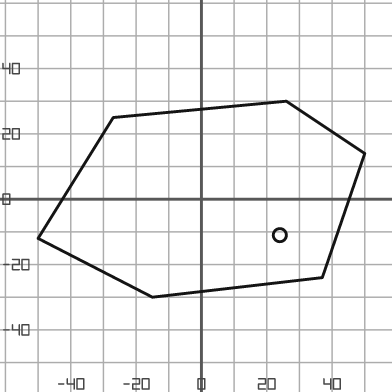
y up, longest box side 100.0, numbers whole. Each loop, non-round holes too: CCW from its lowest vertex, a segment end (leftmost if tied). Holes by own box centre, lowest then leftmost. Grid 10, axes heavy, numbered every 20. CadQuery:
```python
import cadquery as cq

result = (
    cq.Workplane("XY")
    .moveTo(-15.0, -30.0)
    .lineTo(37.0, -24.0)
    .lineTo(50.0, 14.0)
    .lineTo(26.0, 30.0)
    .lineTo(-27.0, 25.0)
    .lineTo(-50.0, -12.0)
    .close()
    .moveTo(24.0, -11.0)
    .circle(2.0)
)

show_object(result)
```